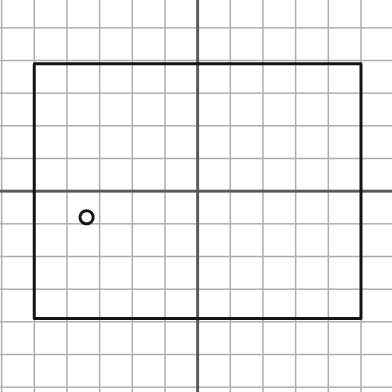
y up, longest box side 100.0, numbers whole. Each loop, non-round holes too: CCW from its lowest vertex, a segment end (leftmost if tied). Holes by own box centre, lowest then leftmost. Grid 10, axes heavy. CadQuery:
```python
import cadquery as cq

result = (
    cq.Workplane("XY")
    .moveTo(-50.0, -39.0)
    .lineTo(50.0, -39.0)
    .lineTo(50.0, 39.0)
    .lineTo(-50.0, 39.0)
    .close()
    .moveTo(-34.0, -8.0)
    .circle(2.0)
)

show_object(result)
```